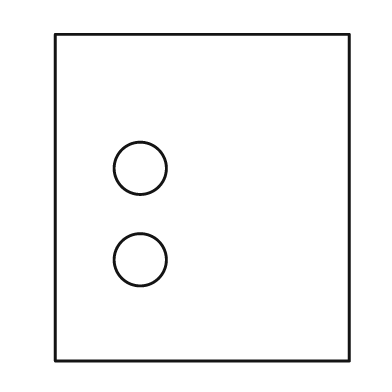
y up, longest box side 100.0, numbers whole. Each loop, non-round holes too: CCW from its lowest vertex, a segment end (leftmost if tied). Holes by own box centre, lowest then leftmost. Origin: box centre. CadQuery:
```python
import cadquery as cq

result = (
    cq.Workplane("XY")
    .moveTo(-45.0, -50.0)
    .lineTo(45.0, -50.0)
    .lineTo(45.0, 50.0)
    .lineTo(-45.0, 50.0)
    .close()
    .moveTo(-19.0, -19.0)
    .circle(8.0)
    .moveTo(-19.0, 9.0)
    .circle(8.0)
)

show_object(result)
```